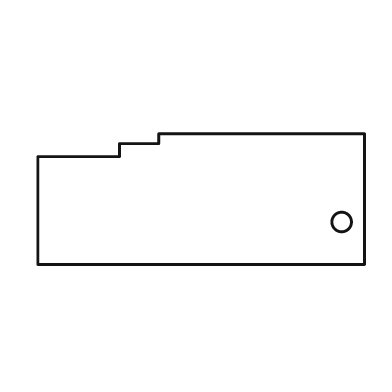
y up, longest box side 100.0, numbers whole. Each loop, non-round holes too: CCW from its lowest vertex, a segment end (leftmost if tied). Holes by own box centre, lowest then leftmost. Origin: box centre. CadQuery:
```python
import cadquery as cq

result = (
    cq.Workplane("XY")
    .moveTo(-50.0, -20.0)
    .lineTo(50.0, -20.0)
    .lineTo(50.0, 20.0)
    .lineTo(-13.0, 20.0)
    .lineTo(-13.0, 17.0)
    .lineTo(-25.0, 17.0)
    .lineTo(-25.0, 13.0)
    .lineTo(-50.0, 13.0)
    .close()
    .moveTo(43.0, -7.0)
    .circle(3.0)
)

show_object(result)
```